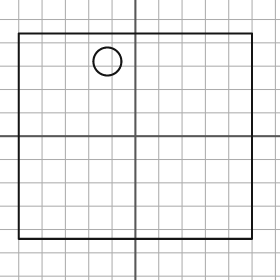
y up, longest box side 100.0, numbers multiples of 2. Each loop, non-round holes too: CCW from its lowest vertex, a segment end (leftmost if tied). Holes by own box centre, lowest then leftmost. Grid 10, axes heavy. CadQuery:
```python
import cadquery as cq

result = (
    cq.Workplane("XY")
    .moveTo(-50.0, -44.0)
    .lineTo(50.0, -44.0)
    .lineTo(50.0, 44.0)
    .lineTo(-50.0, 44.0)
    .close()
    .moveTo(-12.0, 32.0)
    .circle(6.0)
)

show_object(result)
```